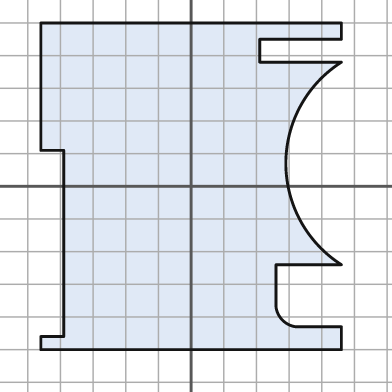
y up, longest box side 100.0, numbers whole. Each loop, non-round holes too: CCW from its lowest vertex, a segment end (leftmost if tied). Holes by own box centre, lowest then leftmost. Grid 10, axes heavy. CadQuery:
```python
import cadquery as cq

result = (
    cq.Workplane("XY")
    .moveTo(-46.0, -50.0)
    .lineTo(46.0, -50.0)
    .lineTo(46.0, -43.0)
    .lineTo(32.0, -43.0)
    .threePointArc((28.0, -41.0), (26.0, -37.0))
    .lineTo(26.0, -24.0)
    .lineTo(46.0, -24.0)
    .threePointArc((29.0, 7.0), (46.0, 38.0))
    .lineTo(21.0, 38.0)
    .lineTo(21.0, 45.0)
    .lineTo(46.0, 45.0)
    .lineTo(46.0, 50.0)
    .lineTo(-46.0, 50.0)
    .lineTo(-46.0, 11.0)
    .lineTo(-39.0, 11.0)
    .lineTo(-39.0, -46.0)
    .lineTo(-46.0, -46.0)
    .close()
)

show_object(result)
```